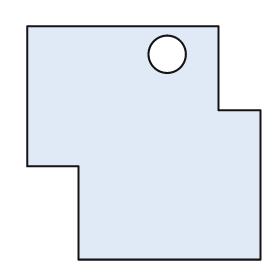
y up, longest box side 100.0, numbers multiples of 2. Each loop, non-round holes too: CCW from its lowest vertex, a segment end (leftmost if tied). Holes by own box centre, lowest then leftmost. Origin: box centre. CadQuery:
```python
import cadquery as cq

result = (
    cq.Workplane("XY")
    .moveTo(-28.0, -50.0)
    .lineTo(50.0, -50.0)
    .lineTo(50.0, 14.0)
    .lineTo(32.0, 14.0)
    .lineTo(32.0, 50.0)
    .lineTo(-50.0, 50.0)
    .lineTo(-50.0, -10.0)
    .lineTo(-28.0, -10.0)
    .close()
    .moveTo(10.0, 38.0)
    .circle(8.0)
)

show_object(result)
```